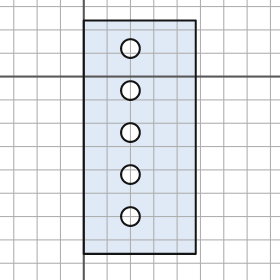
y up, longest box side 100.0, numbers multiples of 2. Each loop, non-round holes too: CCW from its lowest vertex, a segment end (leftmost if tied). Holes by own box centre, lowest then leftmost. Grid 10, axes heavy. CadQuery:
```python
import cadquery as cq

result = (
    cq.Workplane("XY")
    .moveTo(0.0, -76.0)
    .lineTo(48.0, -76.0)
    .lineTo(48.0, 24.0)
    .lineTo(0.0, 24.0)
    .close()
    .moveTo(20.0, -60.0)
    .circle(4.0)
    .moveTo(20.0, -42.0)
    .circle(4.0)
    .moveTo(20.0, -24.0)
    .circle(4.0)
    .moveTo(20.0, -6.0)
    .circle(4.0)
    .moveTo(20.0, 12.0)
    .circle(4.0)
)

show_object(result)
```